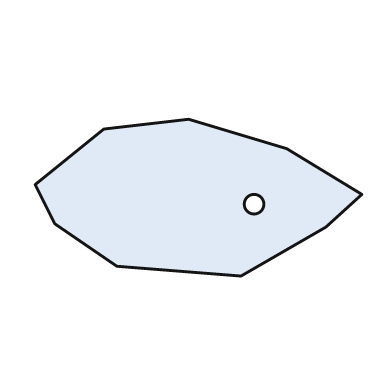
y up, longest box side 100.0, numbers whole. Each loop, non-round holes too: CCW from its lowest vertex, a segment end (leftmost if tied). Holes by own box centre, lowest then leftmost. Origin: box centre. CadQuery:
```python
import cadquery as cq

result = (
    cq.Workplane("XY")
    .moveTo(13.0, -24.0)
    .lineTo(39.0, -9.0)
    .lineTo(50.0, 1.0)
    .lineTo(27.0, 15.0)
    .lineTo(-3.0, 24.0)
    .lineTo(-29.0, 21.0)
    .lineTo(-50.0, 4.0)
    .lineTo(-44.0, -8.0)
    .lineTo(-25.0, -21.0)
    .close()
    .moveTo(17.0, -2.0)
    .circle(3.0)
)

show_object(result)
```